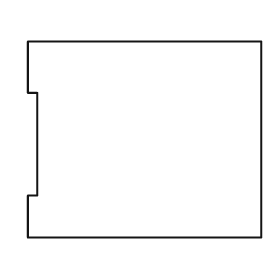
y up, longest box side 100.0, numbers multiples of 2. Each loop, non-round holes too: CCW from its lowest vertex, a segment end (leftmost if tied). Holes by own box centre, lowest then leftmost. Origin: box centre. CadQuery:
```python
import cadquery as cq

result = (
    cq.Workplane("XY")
    .moveTo(-50.0, -42.0)
    .lineTo(50.0, -42.0)
    .lineTo(50.0, 42.0)
    .lineTo(-50.0, 42.0)
    .lineTo(-50.0, 20.0)
    .lineTo(-46.0, 20.0)
    .lineTo(-46.0, -24.0)
    .lineTo(-50.0, -24.0)
    .close()
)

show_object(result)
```